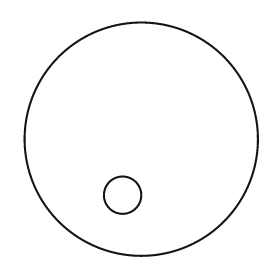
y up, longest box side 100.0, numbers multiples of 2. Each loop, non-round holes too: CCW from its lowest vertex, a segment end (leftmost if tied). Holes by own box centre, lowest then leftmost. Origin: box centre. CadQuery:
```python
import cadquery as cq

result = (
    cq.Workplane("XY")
    .moveTo(0.0, 0.0)
    .circle(50.0)
    .moveTo(-8.0, -24.0)
    .circle(8.0)
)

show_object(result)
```